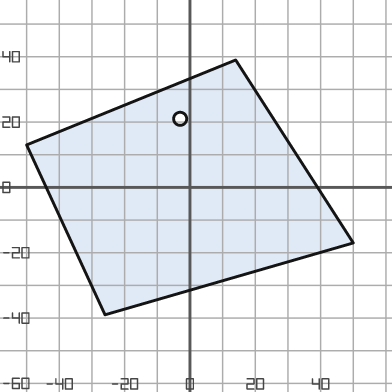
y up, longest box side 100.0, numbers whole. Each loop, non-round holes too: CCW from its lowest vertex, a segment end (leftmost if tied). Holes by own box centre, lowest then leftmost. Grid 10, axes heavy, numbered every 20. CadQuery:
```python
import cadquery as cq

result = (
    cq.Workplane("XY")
    .moveTo(-26.0, -39.0)
    .lineTo(50.0, -17.0)
    .lineTo(14.0, 39.0)
    .lineTo(-50.0, 13.0)
    .close()
    .moveTo(-3.0, 21.0)
    .circle(2.0)
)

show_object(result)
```